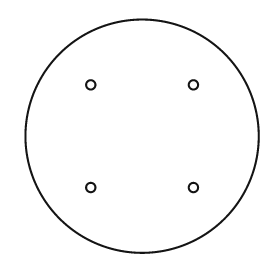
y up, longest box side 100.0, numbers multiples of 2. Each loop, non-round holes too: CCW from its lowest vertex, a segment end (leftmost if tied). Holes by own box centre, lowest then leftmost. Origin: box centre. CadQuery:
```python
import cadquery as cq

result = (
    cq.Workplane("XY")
    .moveTo(0.0, 0.0)
    .circle(50.0)
    .moveTo(-22.0, -22.0)
    .circle(2.0)
    .moveTo(22.0, -22.0)
    .circle(2.0)
    .moveTo(-22.0, 22.0)
    .circle(2.0)
    .moveTo(22.0, 22.0)
    .circle(2.0)
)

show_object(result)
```